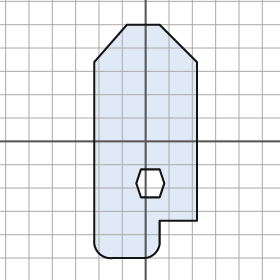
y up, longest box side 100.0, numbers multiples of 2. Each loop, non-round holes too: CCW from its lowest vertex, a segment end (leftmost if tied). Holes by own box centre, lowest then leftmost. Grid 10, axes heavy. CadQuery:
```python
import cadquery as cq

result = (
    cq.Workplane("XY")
    .moveTo(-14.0, -50.0)
    .lineTo(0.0, -50.0)
    .threePointArc((4.0, -48.0), (6.0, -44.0))
    .lineTo(6.0, -34.0)
    .lineTo(22.0, -34.0)
    .lineTo(22.0, 34.0)
    .lineTo(6.0, 50.0)
    .lineTo(-8.0, 50.0)
    .lineTo(-22.0, 34.0)
    .lineTo(-22.0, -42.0)
    .threePointArc((-20.0, -48.0), (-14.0, -50.0))
    .close()
    .moveTo(-2.0, -24.0)
    .lineTo(6.0, -24.0)
    .lineTo(8.0, -18.0)
    .lineTo(6.0, -12.0)
    .lineTo(-2.0, -12.0)
    .lineTo(-4.0, -18.0)
    .close()
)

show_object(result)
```